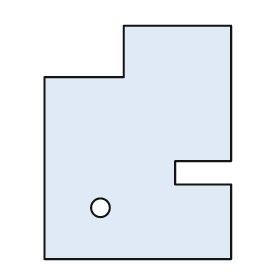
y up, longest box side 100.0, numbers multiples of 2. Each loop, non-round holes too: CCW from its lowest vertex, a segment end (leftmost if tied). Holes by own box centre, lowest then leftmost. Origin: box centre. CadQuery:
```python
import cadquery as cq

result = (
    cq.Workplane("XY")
    .moveTo(-40.0, -50.0)
    .lineTo(40.0, -50.0)
    .lineTo(40.0, -18.0)
    .lineTo(16.0, -18.0)
    .lineTo(16.0, -8.0)
    .lineTo(40.0, -8.0)
    .lineTo(40.0, 50.0)
    .lineTo(-6.0, 50.0)
    .lineTo(-6.0, 28.0)
    .lineTo(-40.0, 28.0)
    .close()
    .moveTo(-16.0, -28.0)
    .circle(4.0)
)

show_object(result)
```